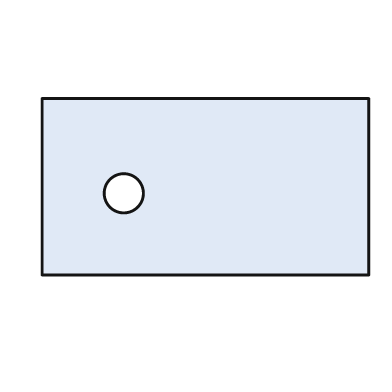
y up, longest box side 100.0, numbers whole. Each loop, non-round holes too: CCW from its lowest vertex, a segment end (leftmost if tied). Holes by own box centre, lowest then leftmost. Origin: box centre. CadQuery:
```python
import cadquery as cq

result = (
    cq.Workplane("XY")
    .moveTo(-50.0, -27.0)
    .lineTo(50.0, -27.0)
    .lineTo(50.0, 27.0)
    .lineTo(-50.0, 27.0)
    .close()
    .moveTo(-25.0, -2.0)
    .circle(6.0)
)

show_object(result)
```